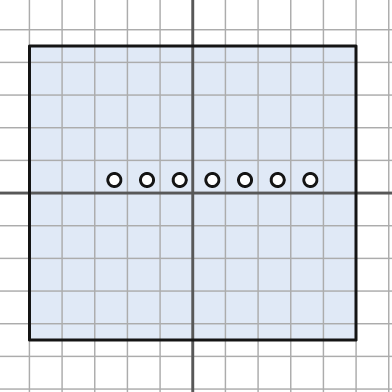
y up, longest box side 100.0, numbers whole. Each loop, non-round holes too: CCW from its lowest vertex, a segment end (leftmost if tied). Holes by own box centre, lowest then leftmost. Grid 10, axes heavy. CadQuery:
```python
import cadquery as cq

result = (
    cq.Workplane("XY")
    .moveTo(-50.0, -45.0)
    .lineTo(50.0, -45.0)
    .lineTo(50.0, 45.0)
    .lineTo(-50.0, 45.0)
    .close()
    .moveTo(-24.0, 4.0)
    .circle(2.0)
    .moveTo(-14.0, 4.0)
    .circle(2.0)
    .moveTo(-4.0, 4.0)
    .circle(2.0)
    .moveTo(6.0, 4.0)
    .circle(2.0)
    .moveTo(16.0, 4.0)
    .circle(2.0)
    .moveTo(26.0, 4.0)
    .circle(2.0)
    .moveTo(36.0, 4.0)
    .circle(2.0)
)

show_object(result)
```